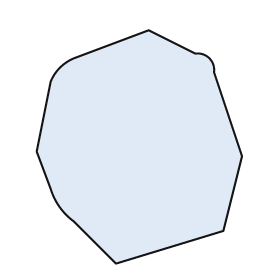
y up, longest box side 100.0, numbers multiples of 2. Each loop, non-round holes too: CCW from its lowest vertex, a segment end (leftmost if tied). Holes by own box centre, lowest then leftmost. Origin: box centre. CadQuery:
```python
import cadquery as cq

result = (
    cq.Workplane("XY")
    .moveTo(-10.0, -50.0)
    .lineTo(36.0, -36.0)
    .lineTo(44.0, -4.0)
    .lineTo(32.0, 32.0)
    .threePointArc((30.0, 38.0), (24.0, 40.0))
    .lineTo(4.0, 50.0)
    .lineTo(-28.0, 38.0)
    .threePointArc((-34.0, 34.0), (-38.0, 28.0))
    .lineTo(-44.0, -2.0)
    .lineTo(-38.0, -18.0)
    .threePointArc((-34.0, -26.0), (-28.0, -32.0))
    .close()
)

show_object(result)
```